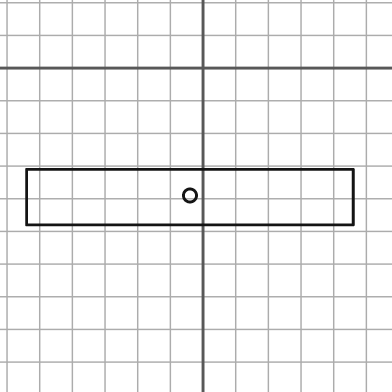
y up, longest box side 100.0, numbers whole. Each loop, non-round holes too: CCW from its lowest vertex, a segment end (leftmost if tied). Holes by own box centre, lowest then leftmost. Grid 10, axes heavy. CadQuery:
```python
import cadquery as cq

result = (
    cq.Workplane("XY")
    .moveTo(-54.0, -48.0)
    .lineTo(46.0, -48.0)
    .lineTo(46.0, -31.0)
    .lineTo(-54.0, -31.0)
    .close()
    .moveTo(-4.0, -39.0)
    .circle(2.0)
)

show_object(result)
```